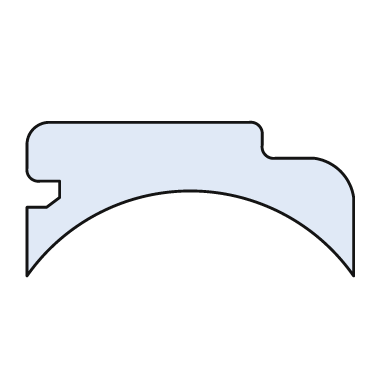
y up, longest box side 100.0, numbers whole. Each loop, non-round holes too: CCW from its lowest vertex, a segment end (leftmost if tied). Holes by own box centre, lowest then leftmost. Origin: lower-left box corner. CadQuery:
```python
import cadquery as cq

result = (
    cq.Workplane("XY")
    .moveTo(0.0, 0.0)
    .threePointArc((50.0, 26.0), (100.0, 0.0))
    .lineTo(100.0, 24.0)
    .threePointArc((96.0, 32.0), (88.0, 36.0))
    .lineTo(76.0, 36.0)
    .threePointArc((73.0, 37.0), (72.0, 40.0))
    .lineTo(72.0, 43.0)
    .threePointArc((71.0, 46.0), (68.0, 47.0))
    .lineTo(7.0, 47.0)
    .threePointArc((2.0, 45.0), (0.0, 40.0))
    .lineTo(0.0, 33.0)
    .threePointArc((1.0, 30.0), (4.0, 29.0))
    .lineTo(10.0, 29.0)
    .lineTo(10.0, 24.0)
    .lineTo(6.0, 21.0)
    .lineTo(0.0, 21.0)
    .close()
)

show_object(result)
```